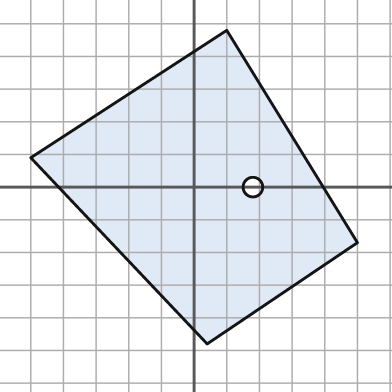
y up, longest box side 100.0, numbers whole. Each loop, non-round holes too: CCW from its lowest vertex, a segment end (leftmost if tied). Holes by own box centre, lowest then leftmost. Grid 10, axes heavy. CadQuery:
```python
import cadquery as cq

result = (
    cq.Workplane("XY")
    .moveTo(4.0, -48.0)
    .lineTo(50.0, -17.0)
    .lineTo(10.0, 48.0)
    .lineTo(-50.0, 9.0)
    .close()
    .moveTo(18.0, 0.0)
    .circle(3.0)
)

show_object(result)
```